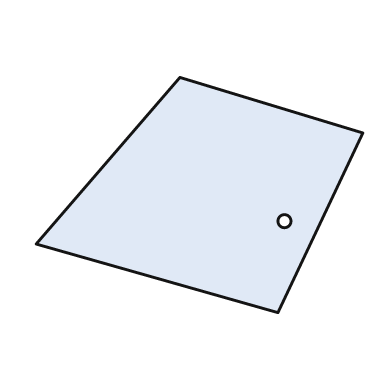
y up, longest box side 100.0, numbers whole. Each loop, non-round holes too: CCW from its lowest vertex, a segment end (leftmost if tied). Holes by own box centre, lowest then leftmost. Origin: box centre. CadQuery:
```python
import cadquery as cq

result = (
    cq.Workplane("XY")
    .moveTo(24.0, -36.0)
    .lineTo(50.0, 19.0)
    .lineTo(-6.0, 36.0)
    .lineTo(-50.0, -15.0)
    .close()
    .moveTo(26.0, -8.0)
    .circle(2.0)
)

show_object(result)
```